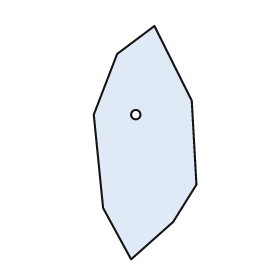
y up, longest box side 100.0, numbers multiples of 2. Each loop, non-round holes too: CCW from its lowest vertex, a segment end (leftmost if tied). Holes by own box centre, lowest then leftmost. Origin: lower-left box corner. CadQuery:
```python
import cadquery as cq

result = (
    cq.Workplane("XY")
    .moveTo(16.0, 0.0)
    .lineTo(34.0, 16.0)
    .lineTo(44.0, 32.0)
    .lineTo(42.0, 68.0)
    .lineTo(26.0, 100.0)
    .lineTo(10.0, 88.0)
    .lineTo(0.0, 62.0)
    .lineTo(4.0, 22.0)
    .close()
    .moveTo(18.0, 62.0)
    .circle(2.0)
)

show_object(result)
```